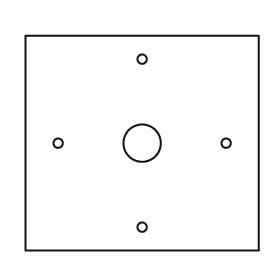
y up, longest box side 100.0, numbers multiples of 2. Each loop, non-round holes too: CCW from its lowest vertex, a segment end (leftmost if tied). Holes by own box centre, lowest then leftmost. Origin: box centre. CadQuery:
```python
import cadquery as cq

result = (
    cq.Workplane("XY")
    .moveTo(-50.0, -46.0)
    .lineTo(50.0, -46.0)
    .lineTo(50.0, 46.0)
    .lineTo(-50.0, 46.0)
    .close()
    .moveTo(0.0, -36.0)
    .circle(2.0)
    .moveTo(-36.0, 0.0)
    .circle(2.0)
    .moveTo(0.0, 0.0)
    .circle(8.0)
    .moveTo(36.0, 0.0)
    .circle(2.0)
    .moveTo(0.0, 36.0)
    .circle(2.0)
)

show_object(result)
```